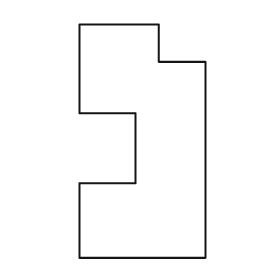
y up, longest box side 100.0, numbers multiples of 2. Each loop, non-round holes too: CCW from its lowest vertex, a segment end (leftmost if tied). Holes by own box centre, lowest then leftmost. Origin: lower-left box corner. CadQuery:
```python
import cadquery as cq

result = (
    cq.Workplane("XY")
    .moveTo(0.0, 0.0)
    .lineTo(54.0, 0.0)
    .lineTo(54.0, 84.0)
    .lineTo(34.0, 84.0)
    .lineTo(34.0, 100.0)
    .lineTo(0.0, 100.0)
    .lineTo(0.0, 62.0)
    .lineTo(24.0, 62.0)
    .lineTo(24.0, 32.0)
    .lineTo(0.0, 32.0)
    .close()
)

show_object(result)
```